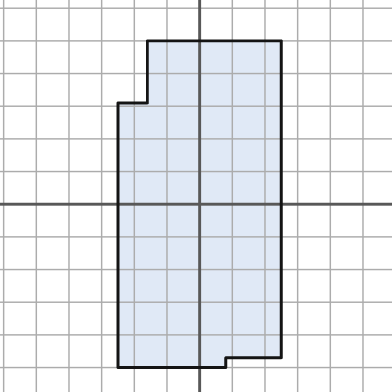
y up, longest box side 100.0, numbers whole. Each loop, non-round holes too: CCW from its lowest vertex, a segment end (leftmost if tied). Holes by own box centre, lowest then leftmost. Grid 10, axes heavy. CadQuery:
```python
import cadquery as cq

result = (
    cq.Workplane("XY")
    .moveTo(-25.0, -50.0)
    .lineTo(8.0, -50.0)
    .lineTo(8.0, -47.0)
    .lineTo(25.0, -47.0)
    .lineTo(25.0, 50.0)
    .lineTo(-16.0, 50.0)
    .lineTo(-16.0, 31.0)
    .lineTo(-25.0, 31.0)
    .close()
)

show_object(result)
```